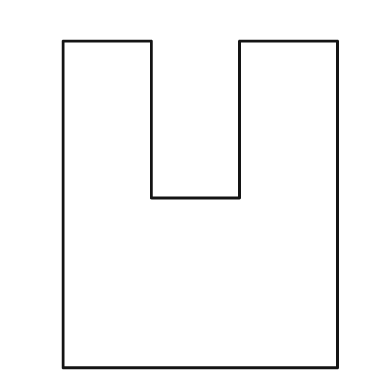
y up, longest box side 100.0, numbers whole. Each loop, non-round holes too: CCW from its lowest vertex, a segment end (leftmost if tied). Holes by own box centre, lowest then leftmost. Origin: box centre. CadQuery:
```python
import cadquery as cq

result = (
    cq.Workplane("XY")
    .moveTo(-42.0, -50.0)
    .lineTo(42.0, -50.0)
    .lineTo(42.0, 50.0)
    .lineTo(12.0, 50.0)
    .lineTo(12.0, 2.0)
    .lineTo(-15.0, 2.0)
    .lineTo(-15.0, 50.0)
    .lineTo(-42.0, 50.0)
    .close()
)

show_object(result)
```